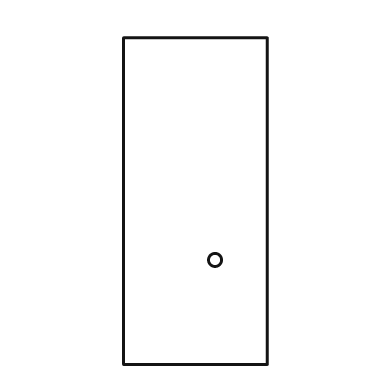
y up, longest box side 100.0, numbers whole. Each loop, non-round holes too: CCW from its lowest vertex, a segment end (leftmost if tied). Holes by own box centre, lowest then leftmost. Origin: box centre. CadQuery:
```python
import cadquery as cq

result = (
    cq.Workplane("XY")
    .moveTo(-22.0, -50.0)
    .lineTo(22.0, -50.0)
    .lineTo(22.0, 50.0)
    .lineTo(-22.0, 50.0)
    .close()
    .moveTo(6.0, -18.0)
    .circle(2.0)
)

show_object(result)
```